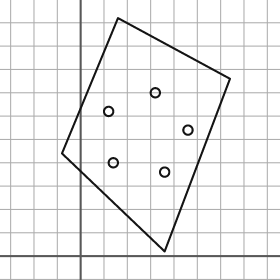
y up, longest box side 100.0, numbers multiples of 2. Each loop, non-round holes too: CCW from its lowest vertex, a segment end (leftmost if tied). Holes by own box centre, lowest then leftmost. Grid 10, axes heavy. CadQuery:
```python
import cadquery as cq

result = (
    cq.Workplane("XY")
    .moveTo(36.0, 2.0)
    .lineTo(64.0, 76.0)
    .lineTo(16.0, 102.0)
    .lineTo(-8.0, 44.0)
    .close()
    .moveTo(36.0, 36.0)
    .circle(2.0)
    .moveTo(14.0, 40.0)
    .circle(2.0)
    .moveTo(46.0, 54.0)
    .circle(2.0)
    .moveTo(12.0, 62.0)
    .circle(2.0)
    .moveTo(32.0, 70.0)
    .circle(2.0)
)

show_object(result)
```